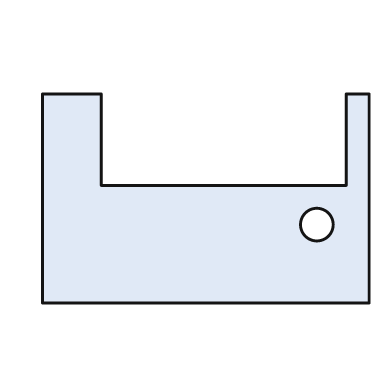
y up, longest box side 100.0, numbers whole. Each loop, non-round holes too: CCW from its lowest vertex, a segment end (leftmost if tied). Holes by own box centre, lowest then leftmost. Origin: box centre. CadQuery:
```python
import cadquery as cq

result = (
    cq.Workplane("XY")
    .moveTo(-50.0, -32.0)
    .lineTo(50.0, -32.0)
    .lineTo(50.0, 32.0)
    .lineTo(43.0, 32.0)
    .lineTo(43.0, 4.0)
    .lineTo(-32.0, 4.0)
    .lineTo(-32.0, 32.0)
    .lineTo(-50.0, 32.0)
    .close()
    .moveTo(34.0, -8.0)
    .circle(5.0)
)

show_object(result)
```